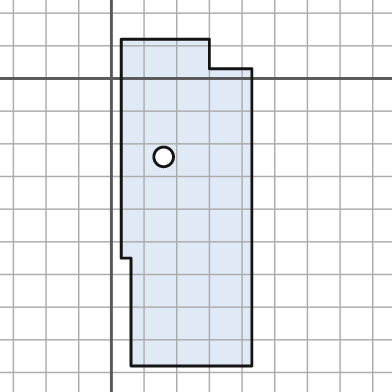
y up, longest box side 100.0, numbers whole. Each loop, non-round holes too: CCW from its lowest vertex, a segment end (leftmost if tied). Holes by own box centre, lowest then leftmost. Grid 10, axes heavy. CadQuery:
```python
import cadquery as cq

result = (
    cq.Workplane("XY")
    .moveTo(6.0, -88.0)
    .lineTo(43.0, -88.0)
    .lineTo(43.0, 3.0)
    .lineTo(30.0, 3.0)
    .lineTo(30.0, 12.0)
    .lineTo(3.0, 12.0)
    .lineTo(3.0, -55.0)
    .lineTo(6.0, -55.0)
    .close()
    .moveTo(16.0, -24.0)
    .circle(3.0)
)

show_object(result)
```